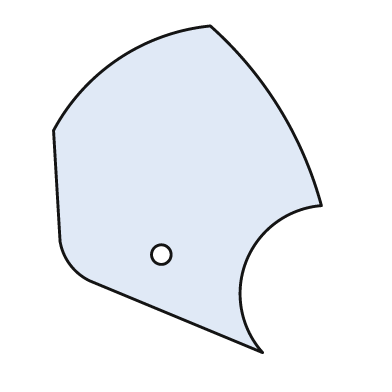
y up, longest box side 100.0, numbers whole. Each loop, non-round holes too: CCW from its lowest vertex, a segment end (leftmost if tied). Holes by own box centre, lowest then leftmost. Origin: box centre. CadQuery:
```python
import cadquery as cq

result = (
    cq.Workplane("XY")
    .moveTo(23.0, -50.0)
    .threePointArc((18.0, -22.0), (41.0, -5.0))
    .threePointArc((28.0, 25.0), (7.0, 50.0))
    .threePointArc((-21.0, 40.0), (-41.0, 18.0))
    .lineTo(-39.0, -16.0)
    .threePointArc((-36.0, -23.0), (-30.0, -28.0))
    .close()
    .moveTo(-8.0, -20.0)
    .circle(3.0)
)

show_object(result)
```